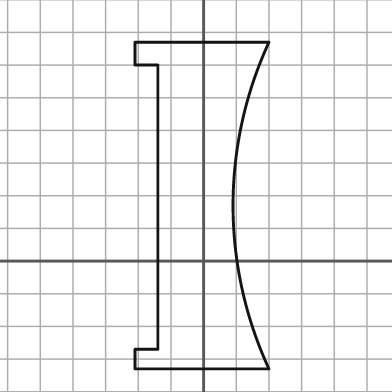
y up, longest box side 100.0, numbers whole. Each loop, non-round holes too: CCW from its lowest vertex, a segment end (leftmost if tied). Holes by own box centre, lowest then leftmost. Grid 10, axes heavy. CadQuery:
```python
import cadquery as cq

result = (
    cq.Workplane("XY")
    .moveTo(-21.0, -33.0)
    .lineTo(20.0, -33.0)
    .threePointArc((9.0, 17.0), (20.0, 67.0))
    .lineTo(-21.0, 67.0)
    .lineTo(-21.0, 60.0)
    .lineTo(-14.0, 60.0)
    .lineTo(-14.0, -27.0)
    .lineTo(-21.0, -27.0)
    .close()
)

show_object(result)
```